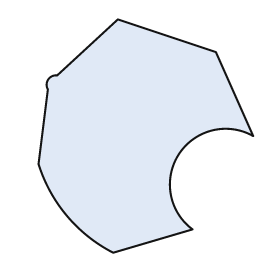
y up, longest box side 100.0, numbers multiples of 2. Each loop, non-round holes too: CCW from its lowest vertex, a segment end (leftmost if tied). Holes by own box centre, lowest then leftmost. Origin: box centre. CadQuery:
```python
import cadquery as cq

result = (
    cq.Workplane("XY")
    .moveTo(-14.0, -50.0)
    .lineTo(20.0, -40.0)
    .threePointArc((14.0, -8.0), (46.0, 0.0))
    .lineTo(30.0, 36.0)
    .lineTo(-12.0, 50.0)
    .lineTo(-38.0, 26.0)
    .threePointArc((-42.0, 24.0), (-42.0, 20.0))
    .lineTo(-46.0, -12.0)
    .threePointArc((-34.0, -34.0), (-14.0, -50.0))
    .close()
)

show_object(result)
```